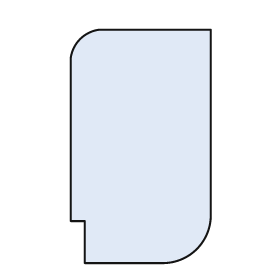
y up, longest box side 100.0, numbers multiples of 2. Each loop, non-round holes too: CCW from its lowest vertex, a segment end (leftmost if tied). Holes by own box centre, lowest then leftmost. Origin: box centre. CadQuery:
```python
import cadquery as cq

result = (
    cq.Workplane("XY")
    .moveTo(-24.0, -50.0)
    .lineTo(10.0, -50.0)
    .threePointArc((24.0, -44.0), (30.0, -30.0))
    .lineTo(30.0, 50.0)
    .lineTo(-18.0, 50.0)
    .threePointArc((-26.0, 46.0), (-30.0, 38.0))
    .lineTo(-30.0, -32.0)
    .lineTo(-24.0, -32.0)
    .close()
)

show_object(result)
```